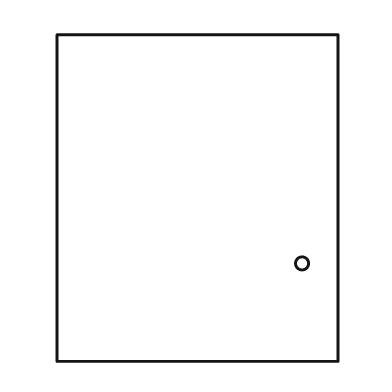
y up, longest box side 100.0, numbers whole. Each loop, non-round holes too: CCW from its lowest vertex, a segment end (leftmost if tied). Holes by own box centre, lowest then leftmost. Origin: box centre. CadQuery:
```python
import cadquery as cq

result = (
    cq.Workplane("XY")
    .moveTo(-43.0, -50.0)
    .lineTo(43.0, -50.0)
    .lineTo(43.0, 50.0)
    .lineTo(-43.0, 50.0)
    .close()
    .moveTo(32.0, -20.0)
    .circle(2.0)
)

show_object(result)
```